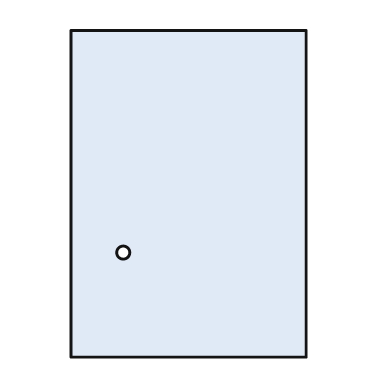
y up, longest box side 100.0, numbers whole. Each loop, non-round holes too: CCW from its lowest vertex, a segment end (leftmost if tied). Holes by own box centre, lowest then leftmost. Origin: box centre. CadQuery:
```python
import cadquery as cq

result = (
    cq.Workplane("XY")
    .moveTo(-36.0, -50.0)
    .lineTo(36.0, -50.0)
    .lineTo(36.0, 50.0)
    .lineTo(-36.0, 50.0)
    .close()
    .moveTo(-20.0, -18.0)
    .circle(2.0)
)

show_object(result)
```